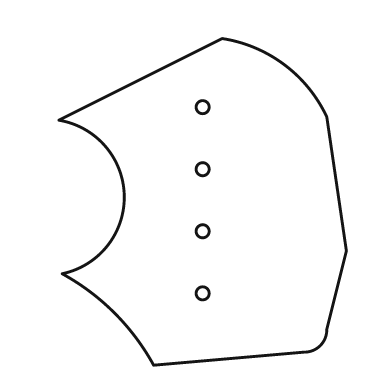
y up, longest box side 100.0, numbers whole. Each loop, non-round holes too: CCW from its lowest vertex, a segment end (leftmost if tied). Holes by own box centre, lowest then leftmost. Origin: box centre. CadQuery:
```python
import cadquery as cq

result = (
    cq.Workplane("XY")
    .moveTo(-15.0, -50.0)
    .lineTo(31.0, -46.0)
    .threePointArc((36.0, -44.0), (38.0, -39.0))
    .lineTo(44.0, -15.0)
    .lineTo(38.0, 26.0)
    .threePointArc((25.0, 42.0), (6.0, 50.0))
    .lineTo(-44.0, 25.0)
    .threePointArc((-24.0, 2.0), (-43.0, -22.0))
    .threePointArc((-27.0, -34.0), (-15.0, -50.0))
    .close()
    .moveTo(0.0, -28.0)
    .circle(2.0)
    .moveTo(0.0, -9.0)
    .circle(2.0)
    .moveTo(0.0, 10.0)
    .circle(2.0)
    .moveTo(0.0, 29.0)
    .circle(2.0)
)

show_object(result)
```